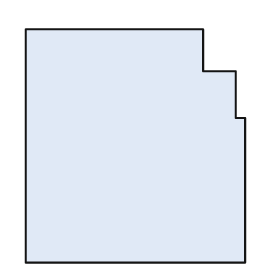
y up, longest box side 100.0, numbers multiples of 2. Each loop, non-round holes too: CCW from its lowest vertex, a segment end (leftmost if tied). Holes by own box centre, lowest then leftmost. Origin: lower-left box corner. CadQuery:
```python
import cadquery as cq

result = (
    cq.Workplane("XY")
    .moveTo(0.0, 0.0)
    .lineTo(94.0, 0.0)
    .lineTo(94.0, 62.0)
    .lineTo(90.0, 62.0)
    .lineTo(90.0, 82.0)
    .lineTo(76.0, 82.0)
    .lineTo(76.0, 100.0)
    .lineTo(0.0, 100.0)
    .close()
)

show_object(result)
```